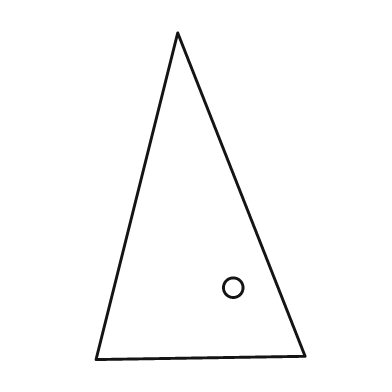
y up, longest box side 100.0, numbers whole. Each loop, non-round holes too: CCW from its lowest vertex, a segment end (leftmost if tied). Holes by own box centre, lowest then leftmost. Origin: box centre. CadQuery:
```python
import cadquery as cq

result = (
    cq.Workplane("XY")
    .moveTo(-32.0, -50.0)
    .lineTo(32.0, -49.0)
    .lineTo(-7.0, 50.0)
    .close()
    .moveTo(10.0, -28.0)
    .circle(3.0)
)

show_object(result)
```